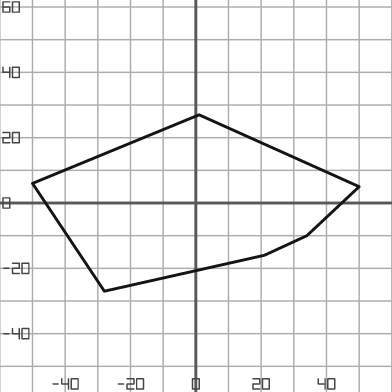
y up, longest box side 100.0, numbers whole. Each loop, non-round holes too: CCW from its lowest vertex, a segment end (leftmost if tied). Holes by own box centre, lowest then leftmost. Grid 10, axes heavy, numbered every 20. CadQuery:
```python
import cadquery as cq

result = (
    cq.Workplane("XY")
    .moveTo(-28.0, -27.0)
    .lineTo(21.0, -16.0)
    .lineTo(34.0, -10.0)
    .lineTo(50.0, 5.0)
    .lineTo(1.0, 27.0)
    .lineTo(-50.0, 6.0)
    .close()
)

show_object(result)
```